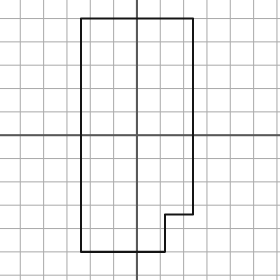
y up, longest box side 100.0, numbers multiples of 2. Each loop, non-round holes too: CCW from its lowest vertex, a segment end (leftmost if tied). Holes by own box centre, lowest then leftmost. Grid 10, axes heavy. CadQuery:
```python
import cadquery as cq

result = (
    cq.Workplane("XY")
    .moveTo(-24.0, -50.0)
    .lineTo(12.0, -50.0)
    .lineTo(12.0, -34.0)
    .lineTo(24.0, -34.0)
    .lineTo(24.0, 50.0)
    .lineTo(-24.0, 50.0)
    .close()
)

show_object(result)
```